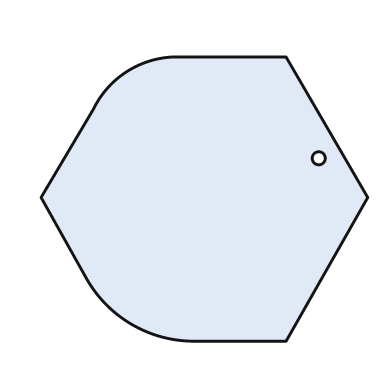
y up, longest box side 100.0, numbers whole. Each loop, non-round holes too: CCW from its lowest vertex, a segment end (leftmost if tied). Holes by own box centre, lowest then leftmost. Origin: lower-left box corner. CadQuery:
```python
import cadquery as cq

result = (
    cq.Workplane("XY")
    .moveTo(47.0, 0.0)
    .lineTo(75.0, 0.0)
    .lineTo(100.0, 44.0)
    .lineTo(75.0, 87.0)
    .lineTo(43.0, 87.0)
    .threePointArc((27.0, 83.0), (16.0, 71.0))
    .lineTo(0.0, 44.0)
    .lineTo(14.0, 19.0)
    .threePointArc((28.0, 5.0), (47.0, 0.0))
    .close()
    .moveTo(85.0, 56.0)
    .circle(2.0)
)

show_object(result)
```